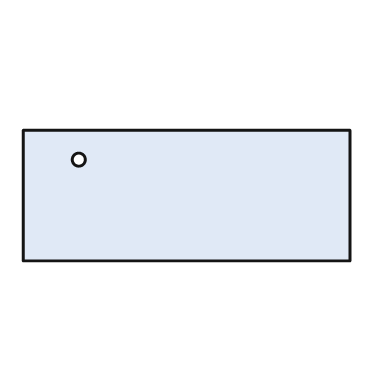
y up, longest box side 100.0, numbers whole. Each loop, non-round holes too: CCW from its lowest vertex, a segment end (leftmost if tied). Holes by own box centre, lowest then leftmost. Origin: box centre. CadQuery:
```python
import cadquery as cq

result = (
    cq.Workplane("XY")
    .moveTo(-50.0, -20.0)
    .lineTo(50.0, -20.0)
    .lineTo(50.0, 20.0)
    .lineTo(-50.0, 20.0)
    .close()
    .moveTo(-33.0, 11.0)
    .circle(2.0)
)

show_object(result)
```